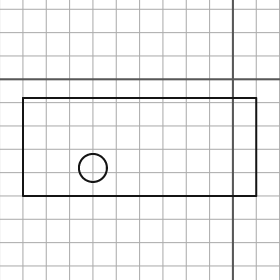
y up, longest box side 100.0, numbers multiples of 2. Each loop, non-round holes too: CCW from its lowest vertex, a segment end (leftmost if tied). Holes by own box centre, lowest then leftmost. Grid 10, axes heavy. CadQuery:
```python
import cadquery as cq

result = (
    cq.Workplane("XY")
    .moveTo(-90.0, -50.0)
    .lineTo(10.0, -50.0)
    .lineTo(10.0, -8.0)
    .lineTo(-90.0, -8.0)
    .close()
    .moveTo(-60.0, -38.0)
    .circle(6.0)
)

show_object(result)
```